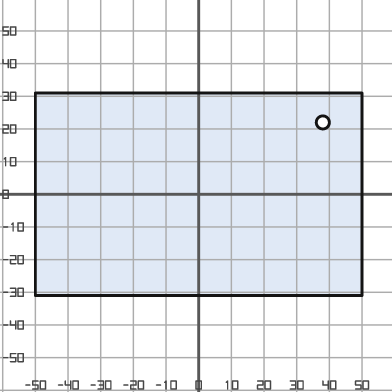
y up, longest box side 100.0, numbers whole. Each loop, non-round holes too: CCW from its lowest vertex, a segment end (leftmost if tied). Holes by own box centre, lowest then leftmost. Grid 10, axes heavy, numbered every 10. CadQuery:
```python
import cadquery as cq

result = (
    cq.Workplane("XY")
    .moveTo(-50.0, -31.0)
    .lineTo(50.0, -31.0)
    .lineTo(50.0, 31.0)
    .lineTo(-50.0, 31.0)
    .close()
    .moveTo(38.0, 22.0)
    .circle(2.0)
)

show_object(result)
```